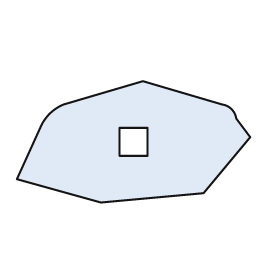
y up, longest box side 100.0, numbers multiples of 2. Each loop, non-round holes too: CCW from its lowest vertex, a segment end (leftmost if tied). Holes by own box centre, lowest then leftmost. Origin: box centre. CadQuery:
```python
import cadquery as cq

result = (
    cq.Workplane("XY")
    .moveTo(-14.0, -26.0)
    .lineTo(30.0, -22.0)
    .lineTo(50.0, 2.0)
    .lineTo(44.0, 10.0)
    .threePointArc((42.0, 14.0), (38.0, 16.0))
    .lineTo(4.0, 26.0)
    .lineTo(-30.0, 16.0)
    .threePointArc((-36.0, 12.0), (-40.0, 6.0))
    .lineTo(-50.0, -16.0)
    .close()
    .moveTo(-6.0, -6.0)
    .lineTo(6.0, -6.0)
    .lineTo(6.0, 6.0)
    .lineTo(-6.0, 6.0)
    .close()
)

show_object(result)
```